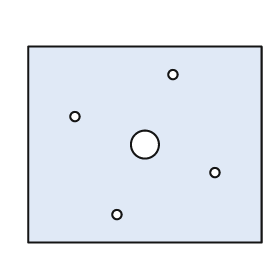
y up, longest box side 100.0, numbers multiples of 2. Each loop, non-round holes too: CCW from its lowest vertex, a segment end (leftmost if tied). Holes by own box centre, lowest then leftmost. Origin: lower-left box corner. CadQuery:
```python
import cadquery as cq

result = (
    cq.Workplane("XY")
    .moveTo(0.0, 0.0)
    .lineTo(100.0, 0.0)
    .lineTo(100.0, 84.0)
    .lineTo(0.0, 84.0)
    .close()
    .moveTo(38.0, 12.0)
    .circle(2.0)
    .moveTo(80.0, 30.0)
    .circle(2.0)
    .moveTo(50.0, 42.0)
    .circle(6.0)
    .moveTo(20.0, 54.0)
    .circle(2.0)
    .moveTo(62.0, 72.0)
    .circle(2.0)
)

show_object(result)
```